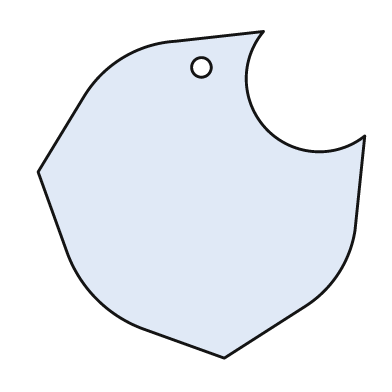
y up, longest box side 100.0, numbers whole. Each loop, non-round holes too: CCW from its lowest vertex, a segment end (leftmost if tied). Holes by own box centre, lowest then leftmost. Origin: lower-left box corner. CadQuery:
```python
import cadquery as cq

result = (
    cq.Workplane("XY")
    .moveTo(57.0, 0.0)
    .lineTo(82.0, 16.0)
    .threePointArc((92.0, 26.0), (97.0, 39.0))
    .lineTo(100.0, 68.0)
    .threePointArc((70.0, 70.0), (69.0, 100.0))
    .lineTo(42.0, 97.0)
    .threePointArc((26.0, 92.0), (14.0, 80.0))
    .lineTo(0.0, 57.0)
    .lineTo(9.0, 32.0)
    .threePointArc((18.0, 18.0), (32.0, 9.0))
    .close()
    .moveTo(50.0, 89.0)
    .circle(3.0)
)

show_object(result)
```